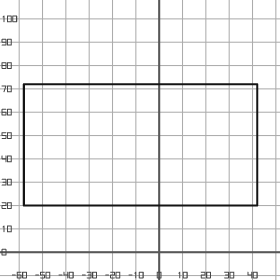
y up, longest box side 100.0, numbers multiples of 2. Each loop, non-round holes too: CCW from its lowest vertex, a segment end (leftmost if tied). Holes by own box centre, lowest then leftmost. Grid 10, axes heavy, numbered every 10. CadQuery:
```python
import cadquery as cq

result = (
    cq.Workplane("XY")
    .moveTo(-58.0, 20.0)
    .lineTo(42.0, 20.0)
    .lineTo(42.0, 72.0)
    .lineTo(-58.0, 72.0)
    .close()
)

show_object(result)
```